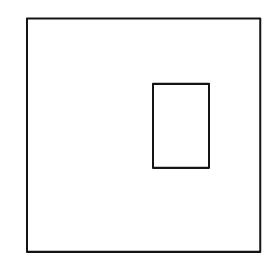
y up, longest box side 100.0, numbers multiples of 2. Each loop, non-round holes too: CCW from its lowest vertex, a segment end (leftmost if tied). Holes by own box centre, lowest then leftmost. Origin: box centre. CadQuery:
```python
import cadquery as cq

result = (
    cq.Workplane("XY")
    .moveTo(-50.0, -50.0)
    .lineTo(50.0, -50.0)
    .lineTo(50.0, 50.0)
    .lineTo(-50.0, 50.0)
    .close()
    .moveTo(4.0, -14.0)
    .lineTo(28.0, -14.0)
    .lineTo(28.0, 22.0)
    .lineTo(4.0, 22.0)
    .close()
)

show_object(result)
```